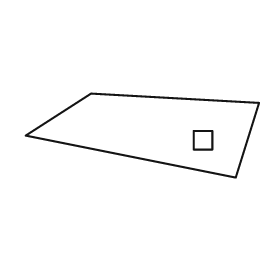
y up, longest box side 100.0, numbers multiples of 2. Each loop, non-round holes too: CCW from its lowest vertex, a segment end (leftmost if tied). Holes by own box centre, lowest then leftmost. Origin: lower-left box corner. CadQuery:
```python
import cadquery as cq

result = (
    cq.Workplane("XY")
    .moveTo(90.0, 0.0)
    .lineTo(100.0, 32.0)
    .lineTo(28.0, 36.0)
    .lineTo(0.0, 18.0)
    .close()
    .moveTo(72.0, 12.0)
    .lineTo(80.0, 12.0)
    .lineTo(80.0, 20.0)
    .lineTo(72.0, 20.0)
    .close()
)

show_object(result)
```